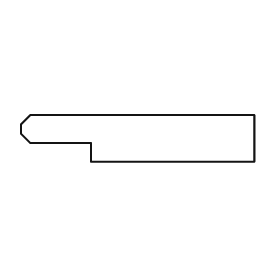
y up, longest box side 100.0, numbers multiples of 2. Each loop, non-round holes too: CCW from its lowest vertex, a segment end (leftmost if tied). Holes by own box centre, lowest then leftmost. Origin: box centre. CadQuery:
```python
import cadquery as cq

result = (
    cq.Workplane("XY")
    .moveTo(-20.0, -10.0)
    .lineTo(50.0, -10.0)
    .lineTo(50.0, 10.0)
    .lineTo(-46.0, 10.0)
    .lineTo(-50.0, 6.0)
    .lineTo(-50.0, 2.0)
    .lineTo(-46.0, -2.0)
    .lineTo(-20.0, -2.0)
    .close()
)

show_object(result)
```